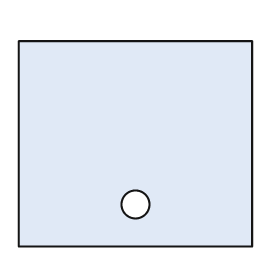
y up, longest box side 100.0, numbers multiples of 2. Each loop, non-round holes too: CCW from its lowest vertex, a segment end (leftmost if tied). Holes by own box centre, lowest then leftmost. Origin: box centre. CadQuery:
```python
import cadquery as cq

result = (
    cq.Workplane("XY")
    .moveTo(-50.0, -44.0)
    .lineTo(50.0, -44.0)
    .lineTo(50.0, 44.0)
    .lineTo(-50.0, 44.0)
    .close()
    .moveTo(0.0, -26.0)
    .circle(6.0)
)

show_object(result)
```